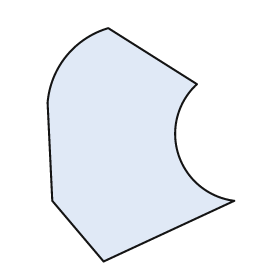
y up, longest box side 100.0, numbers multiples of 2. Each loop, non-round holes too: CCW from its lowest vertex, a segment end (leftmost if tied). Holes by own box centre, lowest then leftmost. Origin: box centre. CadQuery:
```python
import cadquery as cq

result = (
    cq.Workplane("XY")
    .moveTo(-16.0, -50.0)
    .lineTo(40.0, -24.0)
    .threePointArc((16.0, -4.0), (24.0, 26.0))
    .lineTo(-14.0, 50.0)
    .threePointArc((-32.0, 38.0), (-40.0, 18.0))
    .lineTo(-38.0, -24.0)
    .close()
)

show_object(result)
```